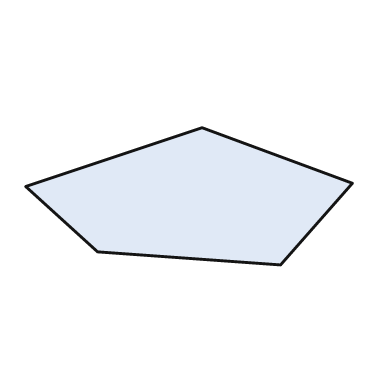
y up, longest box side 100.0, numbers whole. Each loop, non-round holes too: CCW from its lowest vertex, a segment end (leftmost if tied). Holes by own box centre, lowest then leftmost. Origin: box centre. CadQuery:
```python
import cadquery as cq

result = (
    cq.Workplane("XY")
    .moveTo(28.0, -21.0)
    .lineTo(50.0, 4.0)
    .lineTo(4.0, 21.0)
    .lineTo(-50.0, 3.0)
    .lineTo(-28.0, -17.0)
    .close()
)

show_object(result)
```